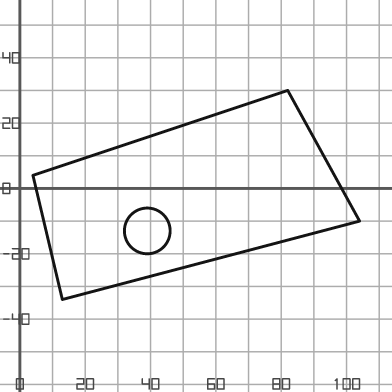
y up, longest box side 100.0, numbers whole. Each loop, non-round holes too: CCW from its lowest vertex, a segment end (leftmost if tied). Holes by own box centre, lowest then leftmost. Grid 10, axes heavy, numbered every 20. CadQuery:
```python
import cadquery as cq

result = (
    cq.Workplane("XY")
    .moveTo(13.0, -34.0)
    .lineTo(104.0, -10.0)
    .lineTo(82.0, 30.0)
    .lineTo(4.0, 4.0)
    .close()
    .moveTo(39.0, -13.0)
    .circle(7.0)
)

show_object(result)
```